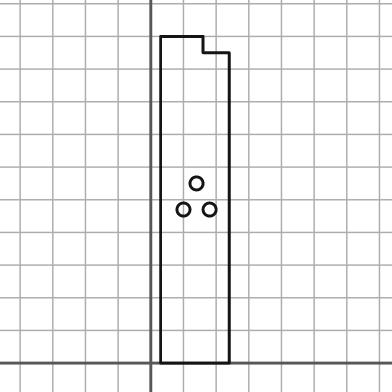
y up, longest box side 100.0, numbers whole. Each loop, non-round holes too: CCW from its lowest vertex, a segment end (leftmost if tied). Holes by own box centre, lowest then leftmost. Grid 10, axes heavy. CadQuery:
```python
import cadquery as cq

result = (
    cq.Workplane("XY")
    .moveTo(3.0, 0.0)
    .lineTo(24.0, 0.0)
    .lineTo(24.0, 95.0)
    .lineTo(16.0, 95.0)
    .lineTo(16.0, 100.0)
    .lineTo(3.0, 100.0)
    .close()
    .moveTo(10.0, 47.0)
    .circle(2.0)
    .moveTo(18.0, 47.0)
    .circle(2.0)
    .moveTo(14.0, 55.0)
    .circle(2.0)
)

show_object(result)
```